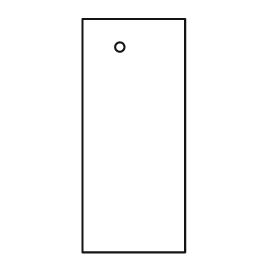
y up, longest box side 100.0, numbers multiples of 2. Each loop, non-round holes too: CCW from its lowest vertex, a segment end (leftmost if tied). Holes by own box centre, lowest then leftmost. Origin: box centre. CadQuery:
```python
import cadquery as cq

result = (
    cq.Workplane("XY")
    .moveTo(-22.0, -50.0)
    .lineTo(22.0, -50.0)
    .lineTo(22.0, 50.0)
    .lineTo(-22.0, 50.0)
    .close()
    .moveTo(-6.0, 38.0)
    .circle(2.0)
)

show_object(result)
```